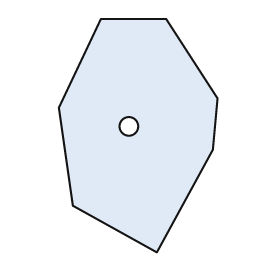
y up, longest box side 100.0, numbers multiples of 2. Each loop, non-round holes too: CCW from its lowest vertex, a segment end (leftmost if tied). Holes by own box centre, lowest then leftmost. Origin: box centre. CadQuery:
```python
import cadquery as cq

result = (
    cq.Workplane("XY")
    .moveTo(8.0, -50.0)
    .lineTo(32.0, -6.0)
    .lineTo(34.0, 16.0)
    .lineTo(12.0, 50.0)
    .lineTo(-16.0, 50.0)
    .lineTo(-34.0, 12.0)
    .lineTo(-28.0, -30.0)
    .close()
    .moveTo(-4.0, 4.0)
    .circle(4.0)
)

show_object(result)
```